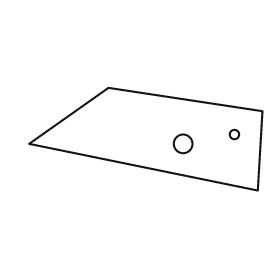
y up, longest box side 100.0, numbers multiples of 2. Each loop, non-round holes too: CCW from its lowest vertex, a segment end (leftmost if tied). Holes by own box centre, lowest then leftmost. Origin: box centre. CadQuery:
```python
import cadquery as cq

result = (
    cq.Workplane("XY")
    .moveTo(48.0, -22.0)
    .lineTo(50.0, 12.0)
    .lineTo(-16.0, 22.0)
    .lineTo(-50.0, -2.0)
    .close()
    .moveTo(16.0, -2.0)
    .circle(4.0)
    .moveTo(38.0, 2.0)
    .circle(2.0)
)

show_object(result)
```